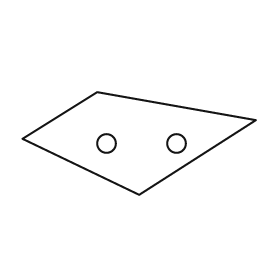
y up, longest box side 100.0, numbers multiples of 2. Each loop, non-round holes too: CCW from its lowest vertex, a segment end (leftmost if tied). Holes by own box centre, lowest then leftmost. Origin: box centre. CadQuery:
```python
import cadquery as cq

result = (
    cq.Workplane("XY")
    .moveTo(0.0, -22.0)
    .lineTo(50.0, 10.0)
    .lineTo(-18.0, 22.0)
    .lineTo(-50.0, 2.0)
    .close()
    .moveTo(-14.0, 0.0)
    .circle(4.0)
    .moveTo(16.0, 0.0)
    .circle(4.0)
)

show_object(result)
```